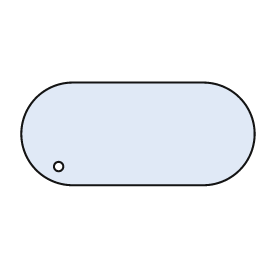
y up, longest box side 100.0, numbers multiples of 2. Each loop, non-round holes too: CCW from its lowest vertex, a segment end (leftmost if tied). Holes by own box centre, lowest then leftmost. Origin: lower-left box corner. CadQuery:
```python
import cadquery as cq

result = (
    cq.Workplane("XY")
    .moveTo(22.0, 0.0)
    .lineTo(78.0, 0.0)
    .threePointArc((100.0, 22.0), (78.0, 44.0))
    .lineTo(22.0, 44.0)
    .threePointArc((0.0, 22.0), (22.0, 0.0))
    .close()
    .moveTo(16.0, 8.0)
    .circle(2.0)
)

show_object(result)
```